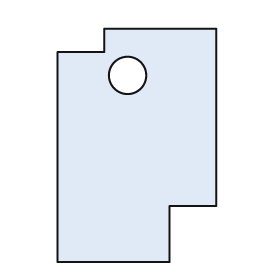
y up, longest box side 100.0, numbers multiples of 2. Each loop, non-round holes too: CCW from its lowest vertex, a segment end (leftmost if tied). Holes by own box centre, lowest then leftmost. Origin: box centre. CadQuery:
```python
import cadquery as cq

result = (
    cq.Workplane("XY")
    .moveTo(-34.0, -50.0)
    .lineTo(14.0, -50.0)
    .lineTo(14.0, -26.0)
    .lineTo(34.0, -26.0)
    .lineTo(34.0, 50.0)
    .lineTo(-14.0, 50.0)
    .lineTo(-14.0, 40.0)
    .lineTo(-34.0, 40.0)
    .close()
    .moveTo(-4.0, 30.0)
    .circle(8.0)
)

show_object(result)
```